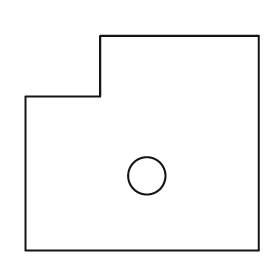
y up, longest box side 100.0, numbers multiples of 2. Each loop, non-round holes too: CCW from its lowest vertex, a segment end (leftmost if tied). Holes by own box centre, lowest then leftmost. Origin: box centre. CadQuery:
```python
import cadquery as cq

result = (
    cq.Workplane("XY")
    .moveTo(-50.0, -46.0)
    .lineTo(50.0, -46.0)
    .lineTo(50.0, 46.0)
    .lineTo(-18.0, 46.0)
    .lineTo(-18.0, 20.0)
    .lineTo(-50.0, 20.0)
    .close()
    .moveTo(2.0, -14.0)
    .circle(8.0)
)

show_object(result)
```